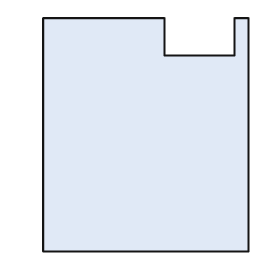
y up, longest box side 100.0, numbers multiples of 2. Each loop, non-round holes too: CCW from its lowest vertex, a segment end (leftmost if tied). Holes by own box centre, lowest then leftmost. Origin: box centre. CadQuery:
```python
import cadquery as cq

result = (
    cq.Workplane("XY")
    .moveTo(-44.0, -50.0)
    .lineTo(44.0, -50.0)
    .lineTo(44.0, 50.0)
    .lineTo(38.0, 50.0)
    .lineTo(38.0, 34.0)
    .lineTo(8.0, 34.0)
    .lineTo(8.0, 50.0)
    .lineTo(-44.0, 50.0)
    .close()
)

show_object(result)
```